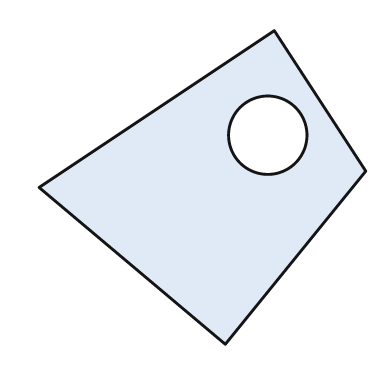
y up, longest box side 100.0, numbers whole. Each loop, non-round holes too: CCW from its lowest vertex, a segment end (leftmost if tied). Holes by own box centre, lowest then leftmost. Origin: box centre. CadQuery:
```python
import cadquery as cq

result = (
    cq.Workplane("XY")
    .moveTo(7.0, -48.0)
    .lineTo(50.0, 5.0)
    .lineTo(22.0, 48.0)
    .lineTo(-50.0, 0.0)
    .close()
    .moveTo(20.0, 16.0)
    .circle(12.0)
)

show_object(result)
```